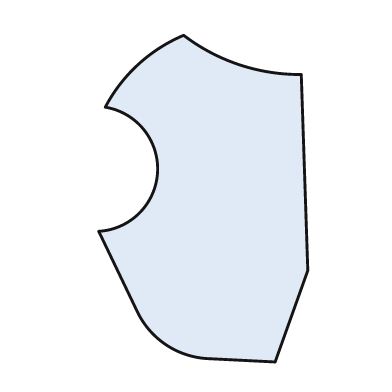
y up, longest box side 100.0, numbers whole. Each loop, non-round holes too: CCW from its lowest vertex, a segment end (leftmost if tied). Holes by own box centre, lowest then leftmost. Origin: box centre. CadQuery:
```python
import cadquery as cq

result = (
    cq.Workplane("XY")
    .moveTo(22.0, -50.0)
    .lineTo(32.0, -22.0)
    .lineTo(30.0, 38.0)
    .threePointArc((11.0, 41.0), (-6.0, 50.0))
    .threePointArc((-20.0, 41.0), (-30.0, 28.0))
    .threePointArc((-14.0, 8.0), (-32.0, -10.0))
    .lineTo(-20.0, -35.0)
    .threePointArc((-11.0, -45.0), (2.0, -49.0))
    .close()
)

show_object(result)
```